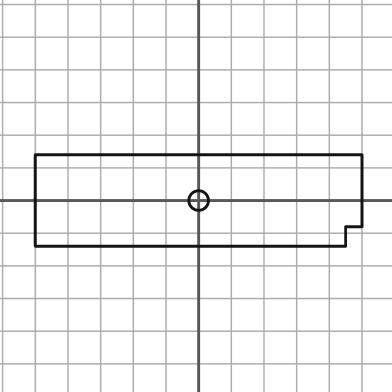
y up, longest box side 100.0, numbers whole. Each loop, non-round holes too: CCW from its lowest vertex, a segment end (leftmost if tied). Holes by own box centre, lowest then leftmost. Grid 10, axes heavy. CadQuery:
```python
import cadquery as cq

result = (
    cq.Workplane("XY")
    .moveTo(-50.0, -14.0)
    .lineTo(45.0, -14.0)
    .lineTo(45.0, -8.0)
    .lineTo(50.0, -8.0)
    .lineTo(50.0, 14.0)
    .lineTo(-50.0, 14.0)
    .close()
    .moveTo(0.0, 0.0)
    .circle(3.0)
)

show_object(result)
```